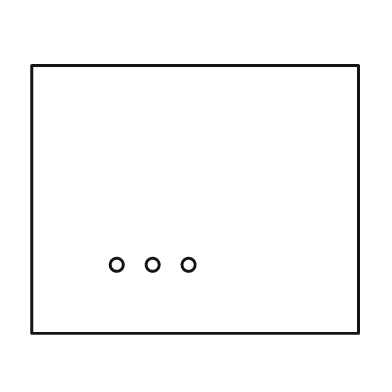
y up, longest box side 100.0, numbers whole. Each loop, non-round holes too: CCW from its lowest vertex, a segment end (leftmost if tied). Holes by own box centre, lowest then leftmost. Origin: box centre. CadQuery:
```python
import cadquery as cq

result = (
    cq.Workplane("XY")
    .moveTo(-50.0, -41.0)
    .lineTo(50.0, -41.0)
    .lineTo(50.0, 41.0)
    .lineTo(-50.0, 41.0)
    .close()
    .moveTo(-24.0, -20.0)
    .circle(2.0)
    .moveTo(-13.0, -20.0)
    .circle(2.0)
    .moveTo(-2.0, -20.0)
    .circle(2.0)
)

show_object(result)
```